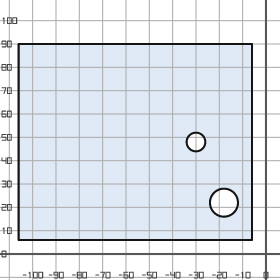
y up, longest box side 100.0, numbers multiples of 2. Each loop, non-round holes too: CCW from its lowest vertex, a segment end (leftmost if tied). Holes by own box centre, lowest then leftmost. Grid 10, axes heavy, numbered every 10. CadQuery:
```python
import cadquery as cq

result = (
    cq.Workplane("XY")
    .moveTo(-106.0, 6.0)
    .lineTo(-6.0, 6.0)
    .lineTo(-6.0, 90.0)
    .lineTo(-106.0, 90.0)
    .close()
    .moveTo(-18.0, 22.0)
    .circle(6.0)
    .moveTo(-30.0, 48.0)
    .circle(4.0)
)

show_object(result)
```